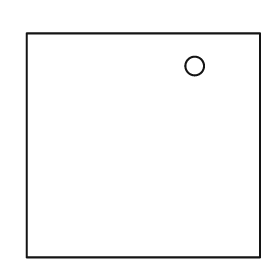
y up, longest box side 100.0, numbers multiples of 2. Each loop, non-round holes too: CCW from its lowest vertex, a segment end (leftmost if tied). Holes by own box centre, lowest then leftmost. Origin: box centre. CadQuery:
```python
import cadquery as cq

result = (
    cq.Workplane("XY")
    .moveTo(-50.0, -48.0)
    .lineTo(50.0, -48.0)
    .lineTo(50.0, 48.0)
    .lineTo(-50.0, 48.0)
    .close()
    .moveTo(22.0, 34.0)
    .circle(4.0)
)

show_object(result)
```